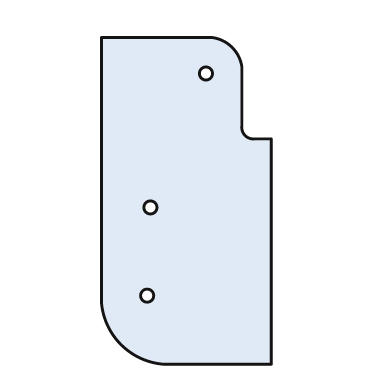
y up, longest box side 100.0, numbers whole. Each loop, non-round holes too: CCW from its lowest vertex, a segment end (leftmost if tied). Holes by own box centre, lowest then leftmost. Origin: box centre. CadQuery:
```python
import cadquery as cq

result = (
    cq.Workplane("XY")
    .moveTo(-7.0, -50.0)
    .lineTo(26.0, -50.0)
    .lineTo(26.0, 19.0)
    .lineTo(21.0, 19.0)
    .threePointArc((18.0, 20.0), (17.0, 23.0))
    .lineTo(17.0, 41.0)
    .threePointArc((14.0, 47.0), (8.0, 50.0))
    .lineTo(-26.0, 50.0)
    .lineTo(-26.0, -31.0)
    .threePointArc((-20.0, -44.0), (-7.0, -50.0))
    .close()
    .moveTo(-12.0, -29.0)
    .circle(2.0)
    .moveTo(-11.0, -2.0)
    .circle(2.0)
    .moveTo(6.0, 39.0)
    .circle(2.0)
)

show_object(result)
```